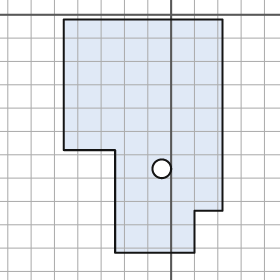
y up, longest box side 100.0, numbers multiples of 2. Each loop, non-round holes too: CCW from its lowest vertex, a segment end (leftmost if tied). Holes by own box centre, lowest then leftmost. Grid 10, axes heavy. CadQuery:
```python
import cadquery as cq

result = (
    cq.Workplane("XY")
    .moveTo(-24.0, -102.0)
    .lineTo(10.0, -102.0)
    .lineTo(10.0, -84.0)
    .lineTo(22.0, -84.0)
    .lineTo(22.0, -2.0)
    .lineTo(-46.0, -2.0)
    .lineTo(-46.0, -58.0)
    .lineTo(-24.0, -58.0)
    .close()
    .moveTo(-4.0, -66.0)
    .circle(4.0)
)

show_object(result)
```